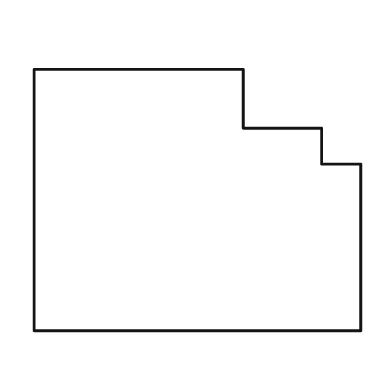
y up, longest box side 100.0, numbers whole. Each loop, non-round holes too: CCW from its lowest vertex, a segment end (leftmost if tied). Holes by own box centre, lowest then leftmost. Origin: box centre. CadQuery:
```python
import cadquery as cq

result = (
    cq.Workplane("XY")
    .moveTo(-50.0, -40.0)
    .lineTo(50.0, -40.0)
    .lineTo(50.0, 11.0)
    .lineTo(38.0, 11.0)
    .lineTo(38.0, 22.0)
    .lineTo(14.0, 22.0)
    .lineTo(14.0, 40.0)
    .lineTo(-50.0, 40.0)
    .close()
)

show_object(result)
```